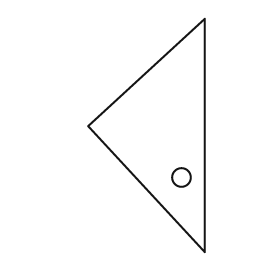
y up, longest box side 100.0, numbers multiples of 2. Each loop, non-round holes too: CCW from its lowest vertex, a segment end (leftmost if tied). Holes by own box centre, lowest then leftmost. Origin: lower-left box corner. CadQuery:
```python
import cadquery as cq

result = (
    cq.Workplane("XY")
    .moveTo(50.0, 0.0)
    .lineTo(50.0, 100.0)
    .lineTo(0.0, 54.0)
    .close()
    .moveTo(40.0, 32.0)
    .circle(4.0)
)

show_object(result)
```